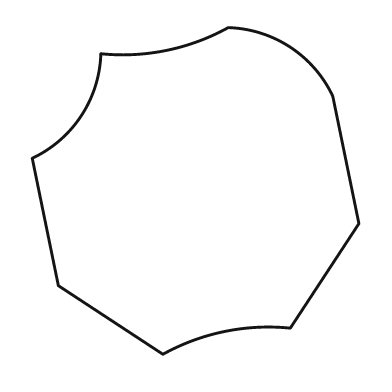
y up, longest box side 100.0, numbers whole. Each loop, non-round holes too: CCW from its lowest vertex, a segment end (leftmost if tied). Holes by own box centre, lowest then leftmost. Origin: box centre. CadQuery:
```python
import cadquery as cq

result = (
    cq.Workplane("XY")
    .moveTo(-10.0, -50.0)
    .threePointArc((9.0, -43.0), (29.0, -42.0))
    .lineTo(50.0, -10.0)
    .lineTo(42.0, 29.0)
    .threePointArc((29.0, 44.0), (10.0, 50.0))
    .threePointArc((-9.0, 43.0), (-29.0, 42.0))
    .threePointArc((-35.0, 23.0), (-50.0, 10.0))
    .lineTo(-42.0, -29.0)
    .close()
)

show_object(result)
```